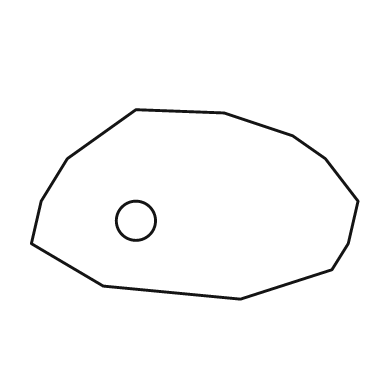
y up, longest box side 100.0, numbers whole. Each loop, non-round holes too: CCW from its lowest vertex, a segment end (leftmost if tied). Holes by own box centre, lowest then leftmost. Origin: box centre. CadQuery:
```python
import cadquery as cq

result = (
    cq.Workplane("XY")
    .moveTo(14.0, -29.0)
    .lineTo(42.0, -20.0)
    .lineTo(47.0, -12.0)
    .lineTo(50.0, 1.0)
    .lineTo(40.0, 14.0)
    .lineTo(30.0, 21.0)
    .lineTo(9.0, 28.0)
    .lineTo(-18.0, 29.0)
    .lineTo(-39.0, 14.0)
    .lineTo(-47.0, 1.0)
    .lineTo(-50.0, -12.0)
    .lineTo(-28.0, -25.0)
    .close()
    .moveTo(-18.0, -5.0)
    .circle(6.0)
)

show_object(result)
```